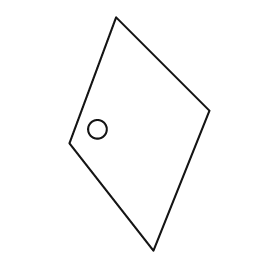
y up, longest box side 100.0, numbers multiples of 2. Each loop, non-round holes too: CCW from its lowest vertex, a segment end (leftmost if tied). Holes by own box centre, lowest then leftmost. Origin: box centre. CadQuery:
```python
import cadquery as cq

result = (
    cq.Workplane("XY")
    .moveTo(6.0, -50.0)
    .lineTo(30.0, 10.0)
    .lineTo(-10.0, 50.0)
    .lineTo(-30.0, -4.0)
    .close()
    .moveTo(-18.0, 2.0)
    .circle(4.0)
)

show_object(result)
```